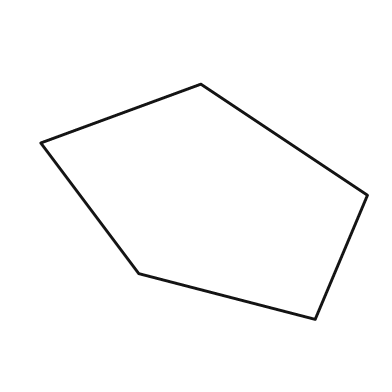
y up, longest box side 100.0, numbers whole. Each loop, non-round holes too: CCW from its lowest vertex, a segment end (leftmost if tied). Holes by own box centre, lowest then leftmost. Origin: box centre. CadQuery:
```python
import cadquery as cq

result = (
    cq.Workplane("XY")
    .moveTo(34.0, -36.0)
    .lineTo(50.0, 2.0)
    .lineTo(-1.0, 36.0)
    .lineTo(-50.0, 18.0)
    .lineTo(-20.0, -22.0)
    .close()
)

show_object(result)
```